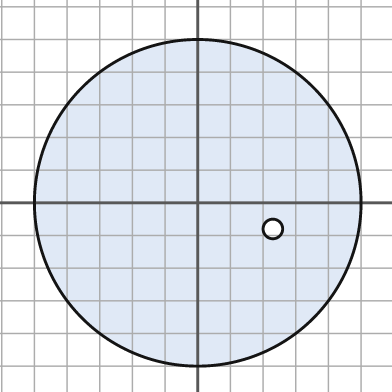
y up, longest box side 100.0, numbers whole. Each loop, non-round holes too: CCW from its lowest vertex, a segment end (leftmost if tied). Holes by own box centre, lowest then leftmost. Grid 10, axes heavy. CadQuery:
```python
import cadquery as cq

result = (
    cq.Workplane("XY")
    .moveTo(0.0, 0.0)
    .circle(50.0)
    .moveTo(23.0, -8.0)
    .circle(3.0)
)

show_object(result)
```